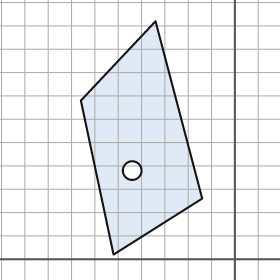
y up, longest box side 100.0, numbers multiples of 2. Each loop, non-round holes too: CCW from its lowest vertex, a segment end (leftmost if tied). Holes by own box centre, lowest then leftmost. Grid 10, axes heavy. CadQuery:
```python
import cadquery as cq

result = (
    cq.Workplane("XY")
    .moveTo(-52.0, 2.0)
    .lineTo(-14.0, 26.0)
    .lineTo(-34.0, 102.0)
    .lineTo(-66.0, 68.0)
    .close()
    .moveTo(-44.0, 38.0)
    .circle(4.0)
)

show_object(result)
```